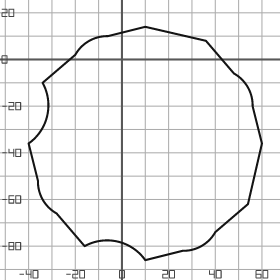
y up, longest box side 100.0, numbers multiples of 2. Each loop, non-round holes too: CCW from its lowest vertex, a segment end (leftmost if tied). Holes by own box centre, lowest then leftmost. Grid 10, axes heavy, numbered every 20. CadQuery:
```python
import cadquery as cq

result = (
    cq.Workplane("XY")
    .moveTo(10.0, -86.0)
    .lineTo(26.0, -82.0)
    .threePointArc((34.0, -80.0), (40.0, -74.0))
    .lineTo(54.0, -62.0)
    .lineTo(60.0, -36.0)
    .lineTo(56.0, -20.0)
    .threePointArc((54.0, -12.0), (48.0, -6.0))
    .lineTo(36.0, 8.0)
    .lineTo(10.0, 14.0)
    .lineTo(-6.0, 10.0)
    .threePointArc((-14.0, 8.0), (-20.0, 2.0))
    .lineTo(-34.0, -10.0)
    .threePointArc((-32.0, -24.0), (-40.0, -36.0))
    .lineTo(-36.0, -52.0)
    .threePointArc((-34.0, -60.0), (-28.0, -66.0))
    .lineTo(-16.0, -80.0)
    .threePointArc((-2.0, -78.0), (10.0, -86.0))
    .close()
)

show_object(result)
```